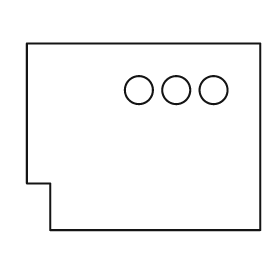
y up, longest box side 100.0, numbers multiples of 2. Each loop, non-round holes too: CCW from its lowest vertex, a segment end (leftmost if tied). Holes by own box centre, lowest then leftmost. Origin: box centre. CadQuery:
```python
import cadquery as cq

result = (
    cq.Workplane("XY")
    .moveTo(-40.0, -40.0)
    .lineTo(50.0, -40.0)
    .lineTo(50.0, 40.0)
    .lineTo(-50.0, 40.0)
    .lineTo(-50.0, -20.0)
    .lineTo(-40.0, -20.0)
    .close()
    .moveTo(-2.0, 20.0)
    .circle(6.0)
    .moveTo(14.0, 20.0)
    .circle(6.0)
    .moveTo(30.0, 20.0)
    .circle(6.0)
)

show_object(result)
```